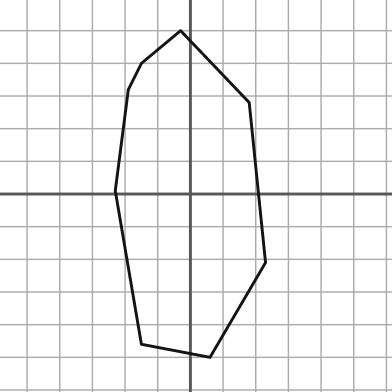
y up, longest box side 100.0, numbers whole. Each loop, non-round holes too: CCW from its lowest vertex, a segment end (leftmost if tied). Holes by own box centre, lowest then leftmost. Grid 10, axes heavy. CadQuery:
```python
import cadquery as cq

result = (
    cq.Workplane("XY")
    .moveTo(6.0, -50.0)
    .lineTo(23.0, -21.0)
    .lineTo(18.0, 28.0)
    .lineTo(-3.0, 50.0)
    .lineTo(-15.0, 40.0)
    .lineTo(-19.0, 32.0)
    .lineTo(-23.0, 1.0)
    .lineTo(-15.0, -46.0)
    .close()
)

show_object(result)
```